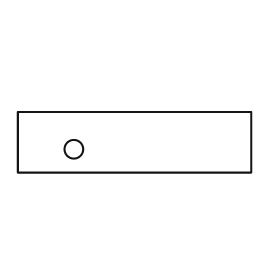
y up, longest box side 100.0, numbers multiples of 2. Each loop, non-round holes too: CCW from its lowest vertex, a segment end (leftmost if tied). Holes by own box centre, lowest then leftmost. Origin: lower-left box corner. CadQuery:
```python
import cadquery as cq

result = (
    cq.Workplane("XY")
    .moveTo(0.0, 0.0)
    .lineTo(100.0, 0.0)
    .lineTo(100.0, 26.0)
    .lineTo(0.0, 26.0)
    .close()
    .moveTo(24.0, 10.0)
    .circle(4.0)
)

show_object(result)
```